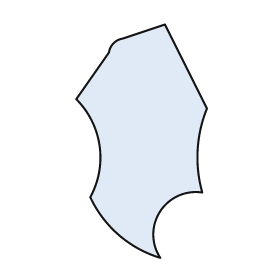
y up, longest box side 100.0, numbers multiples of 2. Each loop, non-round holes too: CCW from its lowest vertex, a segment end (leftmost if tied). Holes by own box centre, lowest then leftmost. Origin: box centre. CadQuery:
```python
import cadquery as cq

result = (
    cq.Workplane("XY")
    .moveTo(8.0, -50.0)
    .threePointArc((8.0, -30.0), (26.0, -22.0))
    .threePointArc((24.0, -4.0), (28.0, 14.0))
    .lineTo(10.0, 50.0)
    .lineTo(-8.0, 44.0)
    .threePointArc((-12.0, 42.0), (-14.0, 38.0))
    .lineTo(-28.0, 18.0)
    .threePointArc((-18.0, -2.0), (-22.0, -24.0))
    .threePointArc((-10.0, -40.0), (8.0, -50.0))
    .close()
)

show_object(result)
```